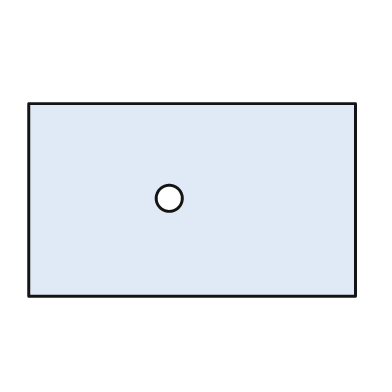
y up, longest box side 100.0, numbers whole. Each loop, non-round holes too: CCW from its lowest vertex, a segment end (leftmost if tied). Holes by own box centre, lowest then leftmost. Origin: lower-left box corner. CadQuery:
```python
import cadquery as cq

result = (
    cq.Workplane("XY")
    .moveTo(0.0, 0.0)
    .lineTo(100.0, 0.0)
    .lineTo(100.0, 59.0)
    .lineTo(0.0, 59.0)
    .close()
    .moveTo(43.0, 30.0)
    .circle(4.0)
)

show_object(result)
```